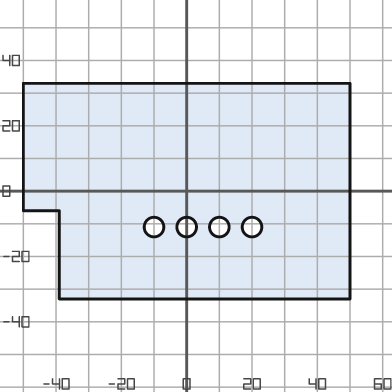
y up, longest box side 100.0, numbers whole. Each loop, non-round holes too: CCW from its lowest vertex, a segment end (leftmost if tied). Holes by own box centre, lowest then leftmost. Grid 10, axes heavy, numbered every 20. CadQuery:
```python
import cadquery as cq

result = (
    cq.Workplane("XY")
    .moveTo(-39.0, -33.0)
    .lineTo(50.0, -33.0)
    .lineTo(50.0, 33.0)
    .lineTo(-50.0, 33.0)
    .lineTo(-50.0, -6.0)
    .lineTo(-39.0, -6.0)
    .close()
    .moveTo(-10.0, -11.0)
    .circle(3.0)
    .moveTo(0.0, -11.0)
    .circle(3.0)
    .moveTo(10.0, -11.0)
    .circle(3.0)
    .moveTo(20.0, -11.0)
    .circle(3.0)
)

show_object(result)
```